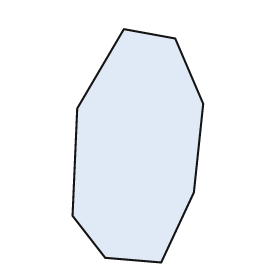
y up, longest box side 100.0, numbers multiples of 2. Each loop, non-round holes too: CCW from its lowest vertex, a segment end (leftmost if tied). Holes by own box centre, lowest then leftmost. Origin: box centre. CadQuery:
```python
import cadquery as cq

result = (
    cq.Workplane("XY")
    .moveTo(10.0, -50.0)
    .lineTo(24.0, -20.0)
    .lineTo(28.0, 18.0)
    .lineTo(16.0, 46.0)
    .lineTo(-6.0, 50.0)
    .lineTo(-26.0, 16.0)
    .lineTo(-28.0, -30.0)
    .lineTo(-14.0, -48.0)
    .close()
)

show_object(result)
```